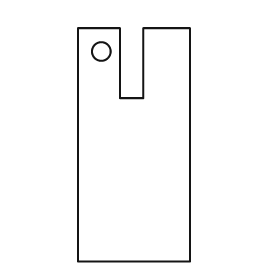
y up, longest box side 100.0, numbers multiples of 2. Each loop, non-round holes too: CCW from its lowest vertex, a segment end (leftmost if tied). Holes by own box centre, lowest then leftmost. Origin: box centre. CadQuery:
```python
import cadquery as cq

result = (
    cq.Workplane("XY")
    .moveTo(-24.0, -50.0)
    .lineTo(24.0, -50.0)
    .lineTo(24.0, 50.0)
    .lineTo(4.0, 50.0)
    .lineTo(4.0, 20.0)
    .lineTo(-6.0, 20.0)
    .lineTo(-6.0, 50.0)
    .lineTo(-24.0, 50.0)
    .close()
    .moveTo(-14.0, 40.0)
    .circle(4.0)
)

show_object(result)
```